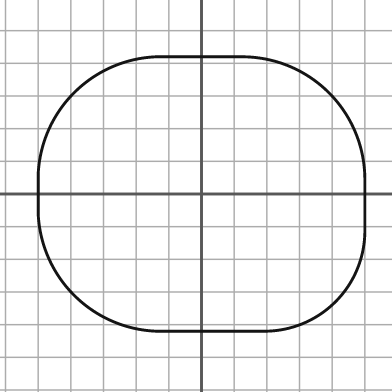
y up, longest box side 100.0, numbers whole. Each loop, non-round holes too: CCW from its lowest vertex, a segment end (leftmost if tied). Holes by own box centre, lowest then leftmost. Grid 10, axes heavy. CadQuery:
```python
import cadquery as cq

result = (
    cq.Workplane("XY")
    .moveTo(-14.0, -42.0)
    .lineTo(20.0, -42.0)
    .threePointArc((41.0, -33.0), (50.0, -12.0))
    .lineTo(50.0, 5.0)
    .threePointArc((39.0, 31.0), (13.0, 42.0))
    .lineTo(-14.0, 42.0)
    .threePointArc((-39.0, 31.0), (-50.0, 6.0))
    .lineTo(-50.0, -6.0)
    .threePointArc((-39.0, -31.0), (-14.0, -42.0))
    .close()
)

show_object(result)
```